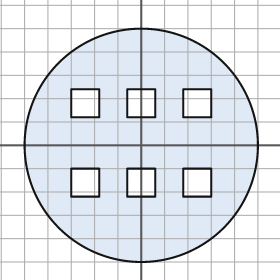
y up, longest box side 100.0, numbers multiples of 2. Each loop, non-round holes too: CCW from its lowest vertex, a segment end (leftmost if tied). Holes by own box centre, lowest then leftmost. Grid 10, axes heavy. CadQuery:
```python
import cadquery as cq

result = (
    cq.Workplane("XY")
    .moveTo(0.0, 0.0)
    .circle(50.0)
    .moveTo(-30.0, -22.0)
    .lineTo(-18.0, -22.0)
    .lineTo(-18.0, -10.0)
    .lineTo(-30.0, -10.0)
    .close()
    .moveTo(-6.0, -22.0)
    .lineTo(6.0, -22.0)
    .lineTo(6.0, -10.0)
    .lineTo(-6.0, -10.0)
    .close()
    .moveTo(18.0, -22.0)
    .lineTo(30.0, -22.0)
    .lineTo(30.0, -10.0)
    .lineTo(18.0, -10.0)
    .close()
    .moveTo(-30.0, 12.0)
    .lineTo(-18.0, 12.0)
    .lineTo(-18.0, 24.0)
    .lineTo(-30.0, 24.0)
    .close()
    .moveTo(-6.0, 12.0)
    .lineTo(6.0, 12.0)
    .lineTo(6.0, 24.0)
    .lineTo(-6.0, 24.0)
    .close()
    .moveTo(18.0, 12.0)
    .lineTo(30.0, 12.0)
    .lineTo(30.0, 24.0)
    .lineTo(18.0, 24.0)
    .close()
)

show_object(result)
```